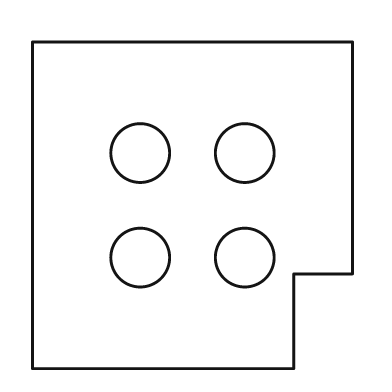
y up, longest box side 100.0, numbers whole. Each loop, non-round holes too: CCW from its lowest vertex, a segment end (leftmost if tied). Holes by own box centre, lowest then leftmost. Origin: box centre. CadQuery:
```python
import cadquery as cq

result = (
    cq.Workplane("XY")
    .moveTo(-49.0, -50.0)
    .lineTo(31.0, -50.0)
    .lineTo(31.0, -21.0)
    .lineTo(49.0, -21.0)
    .lineTo(49.0, 50.0)
    .lineTo(-49.0, 50.0)
    .close()
    .moveTo(-16.0, -16.0)
    .circle(9.0)
    .moveTo(16.0, -16.0)
    .circle(9.0)
    .moveTo(-16.0, 16.0)
    .circle(9.0)
    .moveTo(16.0, 16.0)
    .circle(9.0)
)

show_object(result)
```